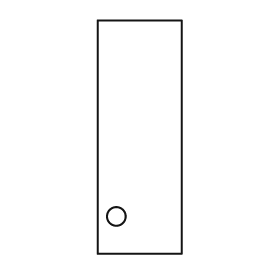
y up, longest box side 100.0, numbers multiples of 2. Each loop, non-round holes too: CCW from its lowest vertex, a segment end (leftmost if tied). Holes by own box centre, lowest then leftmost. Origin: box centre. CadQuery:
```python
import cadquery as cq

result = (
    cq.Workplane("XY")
    .moveTo(-18.0, -50.0)
    .lineTo(18.0, -50.0)
    .lineTo(18.0, 50.0)
    .lineTo(-18.0, 50.0)
    .close()
    .moveTo(-10.0, -34.0)
    .circle(4.0)
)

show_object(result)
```